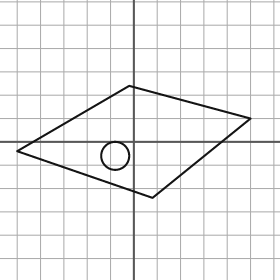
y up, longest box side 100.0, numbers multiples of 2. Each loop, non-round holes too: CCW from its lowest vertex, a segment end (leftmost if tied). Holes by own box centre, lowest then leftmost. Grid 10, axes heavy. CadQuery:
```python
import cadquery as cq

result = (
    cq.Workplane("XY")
    .moveTo(8.0, -24.0)
    .lineTo(50.0, 10.0)
    .lineTo(-2.0, 24.0)
    .lineTo(-50.0, -4.0)
    .close()
    .moveTo(-8.0, -6.0)
    .circle(6.0)
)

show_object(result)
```